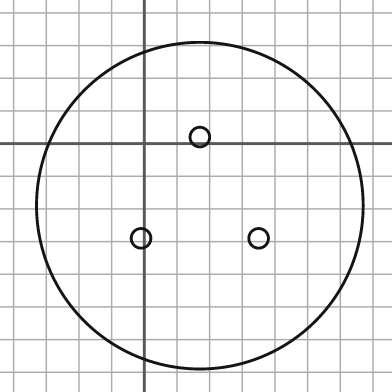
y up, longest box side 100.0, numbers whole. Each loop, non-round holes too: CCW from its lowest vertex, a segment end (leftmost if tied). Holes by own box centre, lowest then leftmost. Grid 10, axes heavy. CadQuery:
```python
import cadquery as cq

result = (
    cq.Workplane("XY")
    .moveTo(17.0, -19.0)
    .circle(50.0)
    .moveTo(-1.0, -29.0)
    .circle(3.0)
    .moveTo(35.0, -29.0)
    .circle(3.0)
    .moveTo(17.0, 2.0)
    .circle(3.0)
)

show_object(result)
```